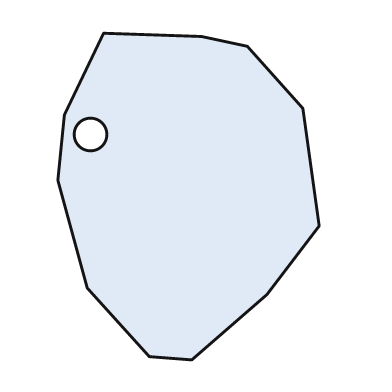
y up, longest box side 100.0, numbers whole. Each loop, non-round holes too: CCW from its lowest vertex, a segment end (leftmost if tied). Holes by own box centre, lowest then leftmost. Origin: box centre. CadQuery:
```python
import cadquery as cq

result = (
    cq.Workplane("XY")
    .moveTo(1.0, -50.0)
    .lineTo(24.0, -30.0)
    .lineTo(40.0, -9.0)
    .lineTo(35.0, 27.0)
    .lineTo(18.0, 46.0)
    .lineTo(4.0, 49.0)
    .lineTo(-26.0, 50.0)
    .lineTo(-38.0, 25.0)
    .lineTo(-40.0, 5.0)
    .lineTo(-31.0, -28.0)
    .lineTo(-12.0, -49.0)
    .close()
    .moveTo(-30.0, 19.0)
    .circle(5.0)
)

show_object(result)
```